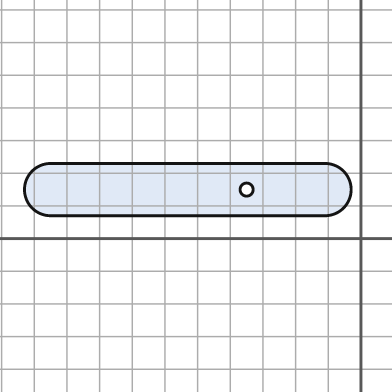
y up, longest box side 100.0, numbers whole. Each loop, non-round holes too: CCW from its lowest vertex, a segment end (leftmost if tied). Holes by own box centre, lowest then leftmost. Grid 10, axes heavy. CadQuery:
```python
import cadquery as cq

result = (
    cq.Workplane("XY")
    .moveTo(-95.0, 7.0)
    .lineTo(-11.0, 7.0)
    .threePointArc((-3.0, 15.0), (-11.0, 23.0))
    .lineTo(-95.0, 23.0)
    .threePointArc((-103.0, 15.0), (-95.0, 7.0))
    .close()
    .moveTo(-35.0, 15.0)
    .circle(2.0)
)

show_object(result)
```